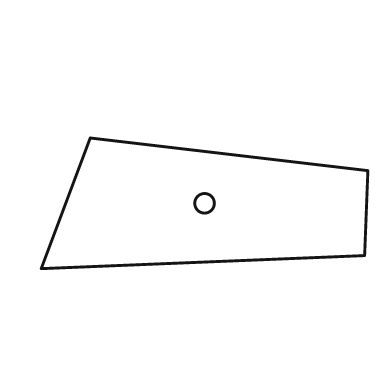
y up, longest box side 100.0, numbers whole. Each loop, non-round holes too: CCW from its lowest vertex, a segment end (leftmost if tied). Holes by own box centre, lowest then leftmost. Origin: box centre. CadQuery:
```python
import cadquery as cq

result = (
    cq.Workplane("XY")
    .moveTo(-50.0, -20.0)
    .lineTo(49.0, -16.0)
    .lineTo(50.0, 10.0)
    .lineTo(-35.0, 20.0)
    .close()
    .moveTo(0.0, 0.0)
    .circle(3.0)
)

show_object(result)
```